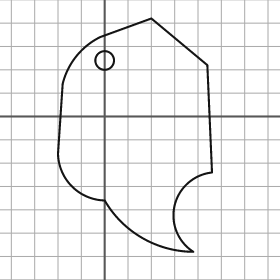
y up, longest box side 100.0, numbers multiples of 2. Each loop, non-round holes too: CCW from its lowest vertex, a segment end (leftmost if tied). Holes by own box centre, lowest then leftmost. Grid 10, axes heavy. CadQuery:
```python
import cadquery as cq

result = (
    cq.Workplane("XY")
    .moveTo(38.0, -58.0)
    .threePointArc((30.0, -38.0), (46.0, -24.0))
    .lineTo(44.0, 22.0)
    .lineTo(20.0, 42.0)
    .lineTo(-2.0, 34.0)
    .threePointArc((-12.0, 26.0), (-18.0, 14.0))
    .lineTo(-20.0, -16.0)
    .threePointArc((-14.0, -30.0), (0.0, -36.0))
    .threePointArc((16.0, -52.0), (38.0, -58.0))
    .close()
    .moveTo(0.0, 24.0)
    .circle(4.0)
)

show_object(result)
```